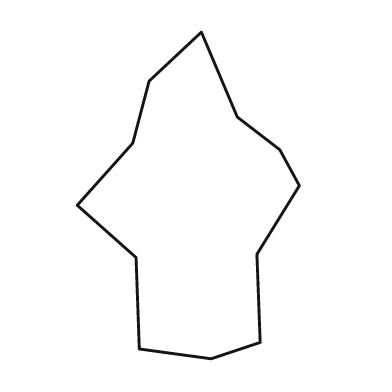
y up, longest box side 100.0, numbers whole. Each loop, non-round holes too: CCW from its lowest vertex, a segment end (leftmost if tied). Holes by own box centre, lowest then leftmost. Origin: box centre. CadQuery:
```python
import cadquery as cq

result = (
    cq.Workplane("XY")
    .moveTo(7.0, -50.0)
    .lineTo(22.0, -45.0)
    .lineTo(21.0, -18.0)
    .lineTo(34.0, 3.0)
    .lineTo(28.0, 14.0)
    .lineTo(15.0, 24.0)
    .lineTo(4.0, 50.0)
    .lineTo(-12.0, 35.0)
    .lineTo(-17.0, 16.0)
    .lineTo(-34.0, -3.0)
    .lineTo(-16.0, -19.0)
    .lineTo(-15.0, -47.0)
    .close()
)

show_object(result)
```